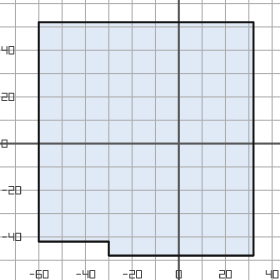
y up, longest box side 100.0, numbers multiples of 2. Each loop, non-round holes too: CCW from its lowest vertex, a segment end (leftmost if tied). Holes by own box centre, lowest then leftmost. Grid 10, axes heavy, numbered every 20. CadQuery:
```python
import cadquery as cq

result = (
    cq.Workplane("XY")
    .moveTo(-30.0, -48.0)
    .lineTo(32.0, -48.0)
    .lineTo(32.0, 52.0)
    .lineTo(-60.0, 52.0)
    .lineTo(-60.0, -42.0)
    .lineTo(-30.0, -42.0)
    .close()
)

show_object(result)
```